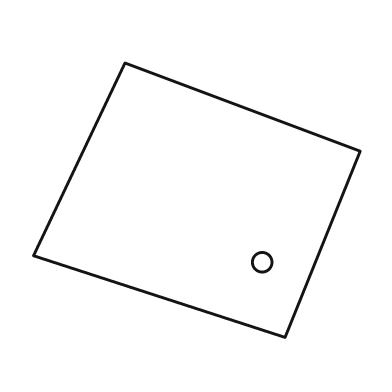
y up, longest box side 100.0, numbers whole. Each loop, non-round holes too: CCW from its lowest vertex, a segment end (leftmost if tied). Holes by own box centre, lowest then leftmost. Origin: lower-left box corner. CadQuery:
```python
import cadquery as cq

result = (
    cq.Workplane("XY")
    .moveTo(77.0, 0.0)
    .lineTo(100.0, 57.0)
    .lineTo(28.0, 84.0)
    .lineTo(0.0, 25.0)
    .close()
    .moveTo(70.0, 23.0)
    .circle(3.0)
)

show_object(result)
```